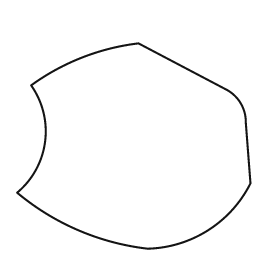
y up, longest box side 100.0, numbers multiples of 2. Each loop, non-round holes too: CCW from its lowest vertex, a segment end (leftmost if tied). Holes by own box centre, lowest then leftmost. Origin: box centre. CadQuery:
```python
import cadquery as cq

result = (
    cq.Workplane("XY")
    .moveTo(6.0, -44.0)
    .threePointArc((32.0, -36.0), (50.0, -16.0))
    .lineTo(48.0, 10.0)
    .threePointArc((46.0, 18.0), (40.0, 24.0))
    .lineTo(2.0, 44.0)
    .threePointArc((-22.0, 38.0), (-44.0, 26.0))
    .threePointArc((-38.0, 2.0), (-50.0, -20.0))
    .threePointArc((-24.0, -36.0), (6.0, -44.0))
    .close()
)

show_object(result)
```